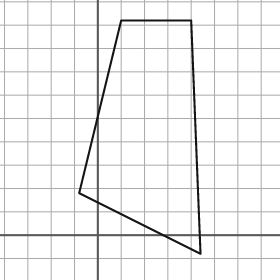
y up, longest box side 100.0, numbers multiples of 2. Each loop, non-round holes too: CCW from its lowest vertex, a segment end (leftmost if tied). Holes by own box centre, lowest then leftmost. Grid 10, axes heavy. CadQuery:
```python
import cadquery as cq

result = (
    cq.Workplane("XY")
    .moveTo(44.0, -8.0)
    .lineTo(40.0, 92.0)
    .lineTo(10.0, 92.0)
    .lineTo(-8.0, 18.0)
    .close()
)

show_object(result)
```